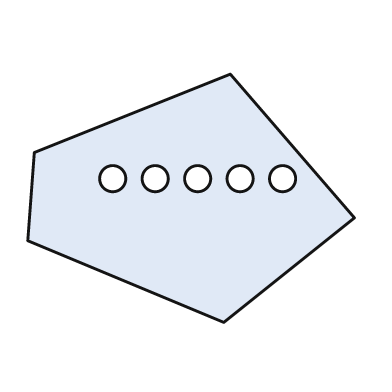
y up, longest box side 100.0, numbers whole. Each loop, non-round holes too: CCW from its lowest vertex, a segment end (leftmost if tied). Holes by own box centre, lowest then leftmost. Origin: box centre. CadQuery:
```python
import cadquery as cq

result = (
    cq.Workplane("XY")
    .moveTo(10.0, -38.0)
    .lineTo(50.0, -6.0)
    .lineTo(12.0, 38.0)
    .lineTo(-48.0, 14.0)
    .lineTo(-50.0, -13.0)
    .close()
    .moveTo(-24.0, 6.0)
    .circle(4.0)
    .moveTo(-11.0, 6.0)
    .circle(4.0)
    .moveTo(2.0, 6.0)
    .circle(4.0)
    .moveTo(15.0, 6.0)
    .circle(4.0)
    .moveTo(28.0, 6.0)
    .circle(4.0)
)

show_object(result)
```